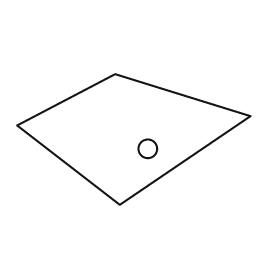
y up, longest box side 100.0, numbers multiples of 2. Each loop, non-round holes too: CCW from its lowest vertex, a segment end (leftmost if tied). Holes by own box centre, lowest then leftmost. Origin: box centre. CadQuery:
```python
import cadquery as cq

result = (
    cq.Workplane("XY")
    .moveTo(-6.0, -28.0)
    .lineTo(50.0, 10.0)
    .lineTo(-8.0, 28.0)
    .lineTo(-50.0, 6.0)
    .close()
    .moveTo(6.0, -4.0)
    .circle(4.0)
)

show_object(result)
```